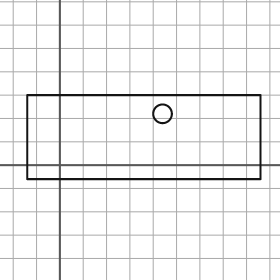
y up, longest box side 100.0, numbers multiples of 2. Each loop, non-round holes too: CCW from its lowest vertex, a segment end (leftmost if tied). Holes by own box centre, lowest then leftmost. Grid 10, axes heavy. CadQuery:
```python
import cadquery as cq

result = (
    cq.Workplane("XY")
    .moveTo(-14.0, -6.0)
    .lineTo(86.0, -6.0)
    .lineTo(86.0, 30.0)
    .lineTo(-14.0, 30.0)
    .close()
    .moveTo(44.0, 22.0)
    .circle(4.0)
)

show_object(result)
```